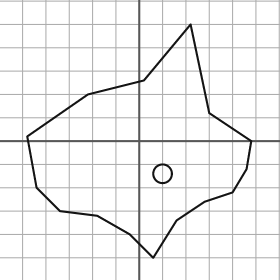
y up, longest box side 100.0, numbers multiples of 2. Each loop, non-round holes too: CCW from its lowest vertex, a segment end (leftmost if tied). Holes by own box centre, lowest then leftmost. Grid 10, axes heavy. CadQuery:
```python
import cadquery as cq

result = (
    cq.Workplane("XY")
    .moveTo(6.0, -50.0)
    .lineTo(16.0, -34.0)
    .lineTo(28.0, -26.0)
    .lineTo(40.0, -22.0)
    .lineTo(46.0, -12.0)
    .lineTo(48.0, 0.0)
    .lineTo(30.0, 12.0)
    .lineTo(22.0, 50.0)
    .lineTo(2.0, 26.0)
    .lineTo(-22.0, 20.0)
    .lineTo(-48.0, 2.0)
    .lineTo(-44.0, -20.0)
    .lineTo(-34.0, -30.0)
    .lineTo(-18.0, -32.0)
    .lineTo(-4.0, -40.0)
    .close()
    .moveTo(10.0, -14.0)
    .circle(4.0)
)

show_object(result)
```